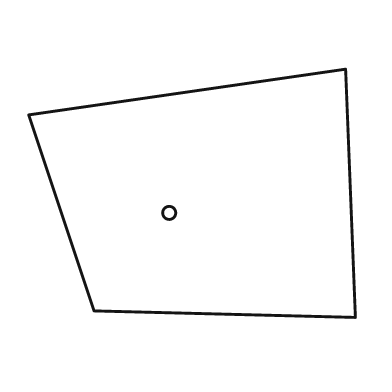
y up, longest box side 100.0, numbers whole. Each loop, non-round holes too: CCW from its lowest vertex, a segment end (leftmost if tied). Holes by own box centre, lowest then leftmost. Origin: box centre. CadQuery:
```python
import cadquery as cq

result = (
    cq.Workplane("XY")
    .moveTo(50.0, -38.0)
    .lineTo(47.0, 38.0)
    .lineTo(-50.0, 24.0)
    .lineTo(-30.0, -36.0)
    .close()
    .moveTo(-7.0, -6.0)
    .circle(2.0)
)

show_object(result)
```